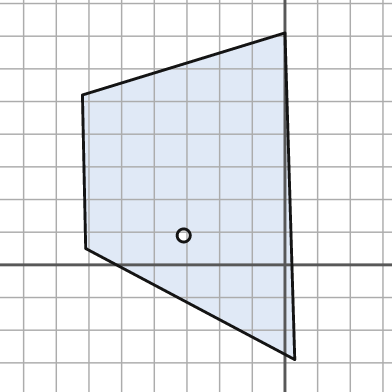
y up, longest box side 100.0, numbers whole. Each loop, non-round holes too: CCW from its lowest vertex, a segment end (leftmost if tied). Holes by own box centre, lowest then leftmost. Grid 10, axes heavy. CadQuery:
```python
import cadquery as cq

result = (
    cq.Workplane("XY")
    .moveTo(3.0, -29.0)
    .lineTo(0.0, 71.0)
    .lineTo(-62.0, 52.0)
    .lineTo(-61.0, 5.0)
    .close()
    .moveTo(-31.0, 9.0)
    .circle(2.0)
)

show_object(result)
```